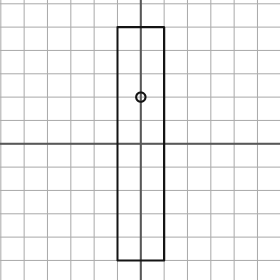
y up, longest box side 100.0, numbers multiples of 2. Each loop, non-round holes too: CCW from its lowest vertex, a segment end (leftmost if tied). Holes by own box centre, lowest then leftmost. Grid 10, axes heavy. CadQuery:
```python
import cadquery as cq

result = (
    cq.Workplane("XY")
    .moveTo(-10.0, -50.0)
    .lineTo(10.0, -50.0)
    .lineTo(10.0, 50.0)
    .lineTo(-10.0, 50.0)
    .close()
    .moveTo(0.0, 20.0)
    .circle(2.0)
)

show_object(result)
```